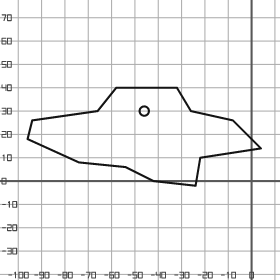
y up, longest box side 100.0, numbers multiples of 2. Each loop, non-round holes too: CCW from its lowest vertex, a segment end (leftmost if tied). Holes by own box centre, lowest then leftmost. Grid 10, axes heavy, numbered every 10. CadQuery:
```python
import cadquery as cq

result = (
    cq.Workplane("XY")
    .moveTo(-24.0, -2.0)
    .lineTo(-22.0, 10.0)
    .lineTo(4.0, 14.0)
    .lineTo(-8.0, 26.0)
    .lineTo(-26.0, 30.0)
    .lineTo(-32.0, 40.0)
    .lineTo(-58.0, 40.0)
    .lineTo(-66.0, 30.0)
    .lineTo(-94.0, 26.0)
    .lineTo(-96.0, 18.0)
    .lineTo(-74.0, 8.0)
    .lineTo(-54.0, 6.0)
    .lineTo(-42.0, 0.0)
    .close()
    .moveTo(-46.0, 30.0)
    .circle(2.0)
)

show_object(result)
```